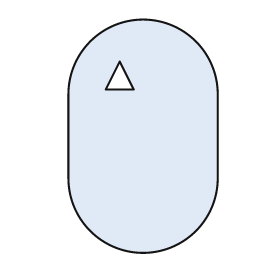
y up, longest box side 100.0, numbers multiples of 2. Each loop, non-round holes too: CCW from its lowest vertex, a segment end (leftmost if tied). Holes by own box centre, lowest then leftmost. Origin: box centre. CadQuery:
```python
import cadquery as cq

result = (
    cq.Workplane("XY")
    .moveTo(-32.0, -18.0)
    .threePointArc((0.0, -50.0), (32.0, -18.0))
    .lineTo(32.0, 18.0)
    .threePointArc((0.0, 50.0), (-32.0, 18.0))
    .close()
    .moveTo(-16.0, 20.0)
    .lineTo(-4.0, 20.0)
    .lineTo(-10.0, 32.0)
    .close()
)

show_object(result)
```